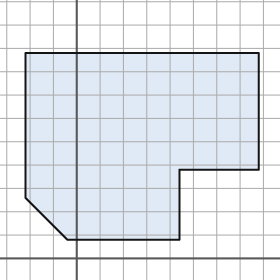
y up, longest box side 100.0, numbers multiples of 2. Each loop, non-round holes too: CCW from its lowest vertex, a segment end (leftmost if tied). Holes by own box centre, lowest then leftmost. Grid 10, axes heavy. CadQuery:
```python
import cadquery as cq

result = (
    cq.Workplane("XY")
    .moveTo(-4.0, 8.0)
    .lineTo(44.0, 8.0)
    .lineTo(44.0, 38.0)
    .lineTo(78.0, 38.0)
    .lineTo(78.0, 88.0)
    .lineTo(-22.0, 88.0)
    .lineTo(-22.0, 26.0)
    .close()
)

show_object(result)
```